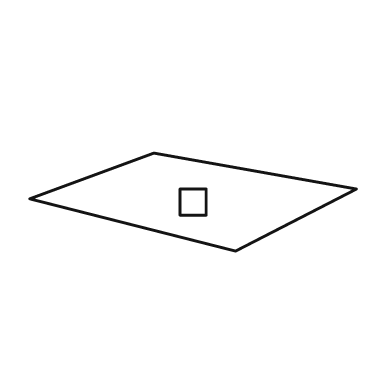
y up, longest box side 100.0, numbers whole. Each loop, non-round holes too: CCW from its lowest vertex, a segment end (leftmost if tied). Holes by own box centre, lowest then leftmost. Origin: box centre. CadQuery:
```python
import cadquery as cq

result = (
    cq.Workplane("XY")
    .moveTo(13.0, -15.0)
    .lineTo(50.0, 4.0)
    .lineTo(-12.0, 15.0)
    .lineTo(-50.0, 1.0)
    .close()
    .moveTo(-4.0, -4.0)
    .lineTo(4.0, -4.0)
    .lineTo(4.0, 4.0)
    .lineTo(-4.0, 4.0)
    .close()
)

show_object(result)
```